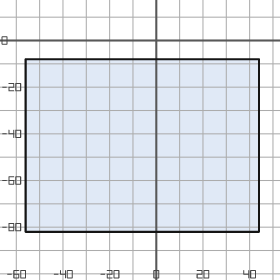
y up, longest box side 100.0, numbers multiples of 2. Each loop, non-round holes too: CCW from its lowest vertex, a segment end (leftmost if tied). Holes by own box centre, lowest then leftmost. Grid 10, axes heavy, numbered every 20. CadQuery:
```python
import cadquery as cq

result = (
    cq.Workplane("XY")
    .moveTo(-56.0, -82.0)
    .lineTo(44.0, -82.0)
    .lineTo(44.0, -8.0)
    .lineTo(-56.0, -8.0)
    .close()
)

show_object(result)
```